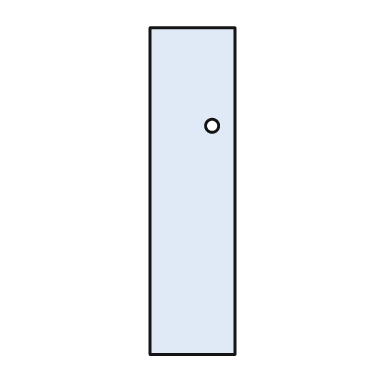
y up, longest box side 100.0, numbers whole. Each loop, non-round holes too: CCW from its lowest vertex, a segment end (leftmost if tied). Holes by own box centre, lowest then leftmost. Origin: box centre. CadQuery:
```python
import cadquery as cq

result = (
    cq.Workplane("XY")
    .moveTo(-13.0, -50.0)
    .lineTo(13.0, -50.0)
    .lineTo(13.0, 50.0)
    .lineTo(-13.0, 50.0)
    .close()
    .moveTo(6.0, 20.0)
    .circle(2.0)
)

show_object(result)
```